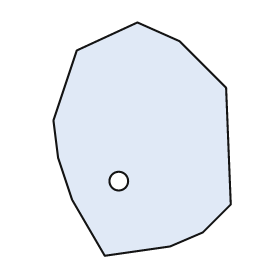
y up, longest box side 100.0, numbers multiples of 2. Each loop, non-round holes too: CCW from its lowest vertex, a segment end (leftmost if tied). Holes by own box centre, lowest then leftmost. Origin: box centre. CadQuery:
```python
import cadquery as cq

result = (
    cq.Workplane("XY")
    .moveTo(-16.0, -50.0)
    .lineTo(12.0, -46.0)
    .lineTo(26.0, -40.0)
    .lineTo(38.0, -28.0)
    .lineTo(36.0, 22.0)
    .lineTo(16.0, 42.0)
    .lineTo(-2.0, 50.0)
    .lineTo(-28.0, 38.0)
    .lineTo(-38.0, 8.0)
    .lineTo(-36.0, -8.0)
    .lineTo(-30.0, -26.0)
    .close()
    .moveTo(-10.0, -18.0)
    .circle(4.0)
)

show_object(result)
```